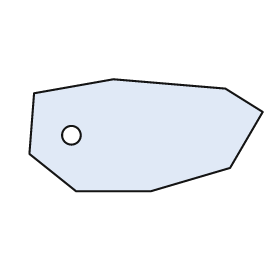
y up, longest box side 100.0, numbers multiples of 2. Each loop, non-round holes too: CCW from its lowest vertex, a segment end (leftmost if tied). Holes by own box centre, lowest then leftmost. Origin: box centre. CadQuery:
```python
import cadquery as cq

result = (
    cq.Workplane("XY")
    .moveTo(-30.0, -24.0)
    .lineTo(2.0, -24.0)
    .lineTo(36.0, -14.0)
    .lineTo(50.0, 10.0)
    .lineTo(34.0, 20.0)
    .lineTo(-14.0, 24.0)
    .lineTo(-48.0, 18.0)
    .lineTo(-50.0, -8.0)
    .close()
    .moveTo(-32.0, 0.0)
    .circle(4.0)
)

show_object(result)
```